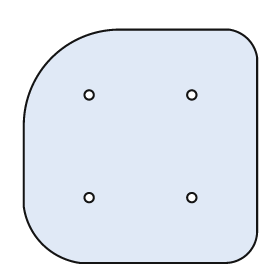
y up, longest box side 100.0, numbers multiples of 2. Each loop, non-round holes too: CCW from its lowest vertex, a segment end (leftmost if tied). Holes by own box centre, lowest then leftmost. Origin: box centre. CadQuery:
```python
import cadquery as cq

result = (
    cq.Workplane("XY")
    .moveTo(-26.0, -50.0)
    .lineTo(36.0, -50.0)
    .threePointArc((46.0, -46.0), (50.0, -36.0))
    .lineTo(50.0, 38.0)
    .threePointArc((46.0, 46.0), (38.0, 50.0))
    .lineTo(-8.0, 50.0)
    .threePointArc((-38.0, 38.0), (-50.0, 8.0))
    .lineTo(-50.0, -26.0)
    .threePointArc((-42.0, -42.0), (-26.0, -50.0))
    .close()
    .moveTo(-22.0, -22.0)
    .circle(2.0)
    .moveTo(22.0, -22.0)
    .circle(2.0)
    .moveTo(-22.0, 22.0)
    .circle(2.0)
    .moveTo(22.0, 22.0)
    .circle(2.0)
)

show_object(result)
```